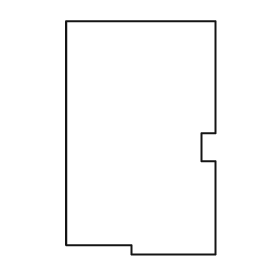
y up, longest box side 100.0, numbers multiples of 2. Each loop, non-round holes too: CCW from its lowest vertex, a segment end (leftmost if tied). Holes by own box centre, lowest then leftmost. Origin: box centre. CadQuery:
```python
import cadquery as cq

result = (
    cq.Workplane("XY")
    .moveTo(-4.0, -50.0)
    .lineTo(32.0, -50.0)
    .lineTo(32.0, -10.0)
    .lineTo(26.0, -10.0)
    .lineTo(26.0, 2.0)
    .lineTo(32.0, 2.0)
    .lineTo(32.0, 50.0)
    .lineTo(-32.0, 50.0)
    .lineTo(-32.0, -46.0)
    .lineTo(-4.0, -46.0)
    .close()
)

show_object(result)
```